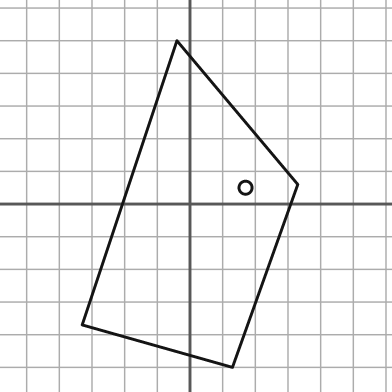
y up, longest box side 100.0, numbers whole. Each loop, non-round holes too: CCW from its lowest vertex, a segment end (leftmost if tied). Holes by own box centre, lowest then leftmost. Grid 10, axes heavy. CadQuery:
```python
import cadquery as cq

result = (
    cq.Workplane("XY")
    .moveTo(13.0, -50.0)
    .lineTo(33.0, 6.0)
    .lineTo(-4.0, 50.0)
    .lineTo(-33.0, -37.0)
    .close()
    .moveTo(17.0, 5.0)
    .circle(2.0)
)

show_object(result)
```